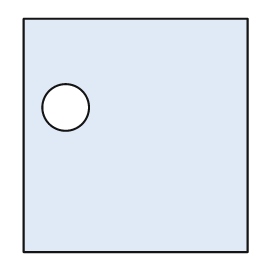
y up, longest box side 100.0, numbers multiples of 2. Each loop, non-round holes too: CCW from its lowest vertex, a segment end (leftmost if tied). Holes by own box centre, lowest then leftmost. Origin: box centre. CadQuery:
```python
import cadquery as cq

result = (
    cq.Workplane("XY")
    .moveTo(-48.0, -50.0)
    .lineTo(48.0, -50.0)
    .lineTo(48.0, 50.0)
    .lineTo(-48.0, 50.0)
    .close()
    .moveTo(-30.0, 12.0)
    .circle(10.0)
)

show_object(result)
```